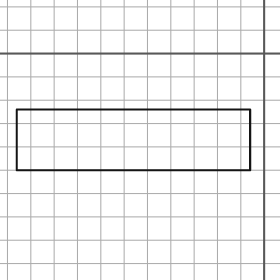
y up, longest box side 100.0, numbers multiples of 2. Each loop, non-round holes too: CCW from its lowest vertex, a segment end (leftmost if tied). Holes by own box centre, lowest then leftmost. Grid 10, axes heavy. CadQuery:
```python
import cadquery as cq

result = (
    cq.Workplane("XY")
    .moveTo(-106.0, -50.0)
    .lineTo(-6.0, -50.0)
    .lineTo(-6.0, -24.0)
    .lineTo(-106.0, -24.0)
    .close()
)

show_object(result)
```